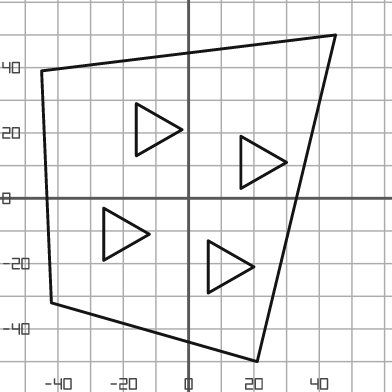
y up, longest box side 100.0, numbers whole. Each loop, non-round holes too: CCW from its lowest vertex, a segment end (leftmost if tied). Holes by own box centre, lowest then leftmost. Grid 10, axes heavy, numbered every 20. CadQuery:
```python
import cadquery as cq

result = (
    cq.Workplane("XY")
    .moveTo(21.0, -50.0)
    .lineTo(45.0, 50.0)
    .lineTo(-45.0, 39.0)
    .lineTo(-42.0, -32.0)
    .close()
    .moveTo(6.0, -29.0)
    .lineTo(20.0, -21.0)
    .lineTo(6.0, -13.0)
    .close()
    .moveTo(-26.0, -19.0)
    .lineTo(-12.0, -11.0)
    .lineTo(-26.0, -3.0)
    .close()
    .moveTo(16.0, 3.0)
    .lineTo(30.0, 11.0)
    .lineTo(16.0, 19.0)
    .close()
    .moveTo(-16.0, 13.0)
    .lineTo(-2.0, 21.0)
    .lineTo(-16.0, 29.0)
    .close()
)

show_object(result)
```